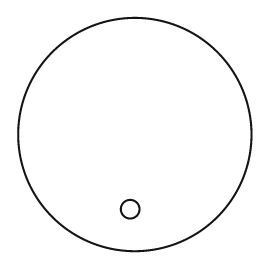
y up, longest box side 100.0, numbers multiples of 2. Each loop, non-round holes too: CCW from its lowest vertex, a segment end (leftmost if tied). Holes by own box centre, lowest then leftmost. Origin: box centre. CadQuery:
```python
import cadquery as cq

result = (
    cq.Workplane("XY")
    .moveTo(0.0, 0.0)
    .circle(50.0)
    .moveTo(-2.0, -32.0)
    .circle(4.0)
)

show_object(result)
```